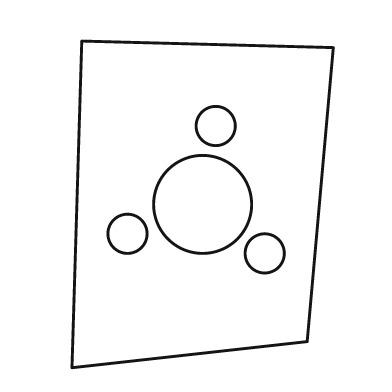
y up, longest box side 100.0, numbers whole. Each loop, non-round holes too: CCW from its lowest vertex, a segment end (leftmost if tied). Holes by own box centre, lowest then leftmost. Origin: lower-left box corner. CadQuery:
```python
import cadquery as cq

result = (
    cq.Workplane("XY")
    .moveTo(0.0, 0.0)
    .lineTo(72.0, 8.0)
    .lineTo(80.0, 98.0)
    .lineTo(3.0, 100.0)
    .close()
    .moveTo(59.0, 35.0)
    .circle(6.0)
    .moveTo(17.0, 41.0)
    .circle(6.0)
    .moveTo(40.0, 50.0)
    .circle(15.0)
    .moveTo(44.0, 74.0)
    .circle(6.0)
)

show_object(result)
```